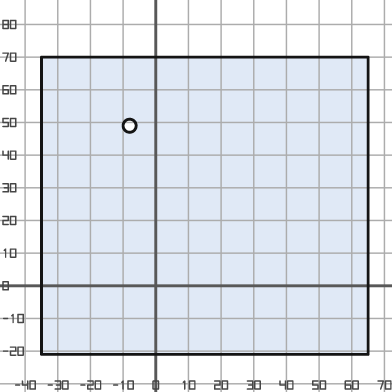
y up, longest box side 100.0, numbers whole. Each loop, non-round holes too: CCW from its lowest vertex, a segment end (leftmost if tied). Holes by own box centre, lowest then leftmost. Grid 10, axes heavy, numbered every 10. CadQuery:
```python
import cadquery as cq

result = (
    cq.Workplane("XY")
    .moveTo(-35.0, -21.0)
    .lineTo(65.0, -21.0)
    .lineTo(65.0, 70.0)
    .lineTo(-35.0, 70.0)
    .close()
    .moveTo(-8.0, 49.0)
    .circle(2.0)
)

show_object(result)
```